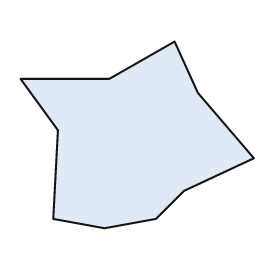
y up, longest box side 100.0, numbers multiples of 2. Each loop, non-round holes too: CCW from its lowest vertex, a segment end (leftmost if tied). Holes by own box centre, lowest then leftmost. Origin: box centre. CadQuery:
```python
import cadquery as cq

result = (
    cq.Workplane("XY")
    .moveTo(-14.0, -40.0)
    .lineTo(8.0, -36.0)
    .lineTo(20.0, -24.0)
    .lineTo(50.0, -10.0)
    .lineTo(26.0, 18.0)
    .lineTo(16.0, 40.0)
    .lineTo(-12.0, 24.0)
    .lineTo(-50.0, 24.0)
    .lineTo(-34.0, 2.0)
    .lineTo(-36.0, -36.0)
    .close()
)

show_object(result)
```